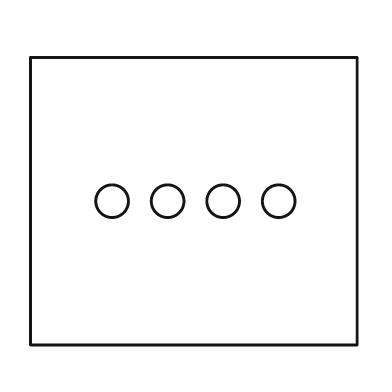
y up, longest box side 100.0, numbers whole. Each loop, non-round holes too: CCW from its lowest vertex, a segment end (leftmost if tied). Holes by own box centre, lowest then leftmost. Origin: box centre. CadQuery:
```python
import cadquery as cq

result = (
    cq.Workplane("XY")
    .moveTo(-50.0, -44.0)
    .lineTo(50.0, -44.0)
    .lineTo(50.0, 44.0)
    .lineTo(-50.0, 44.0)
    .close()
    .moveTo(-25.0, 0.0)
    .circle(5.0)
    .moveTo(-8.0, 0.0)
    .circle(5.0)
    .moveTo(9.0, 0.0)
    .circle(5.0)
    .moveTo(26.0, 0.0)
    .circle(5.0)
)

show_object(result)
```